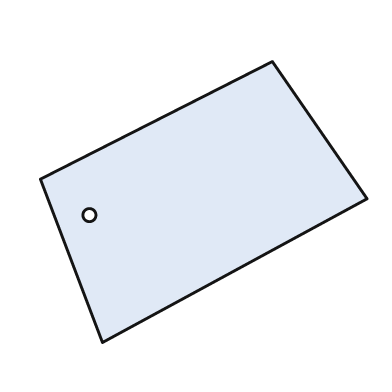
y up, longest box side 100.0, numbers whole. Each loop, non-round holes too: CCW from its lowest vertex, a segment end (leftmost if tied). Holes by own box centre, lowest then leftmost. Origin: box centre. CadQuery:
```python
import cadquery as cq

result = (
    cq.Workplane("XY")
    .moveTo(-31.0, -43.0)
    .lineTo(50.0, 1.0)
    .lineTo(21.0, 43.0)
    .lineTo(-50.0, 7.0)
    .close()
    .moveTo(-35.0, -4.0)
    .circle(2.0)
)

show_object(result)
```